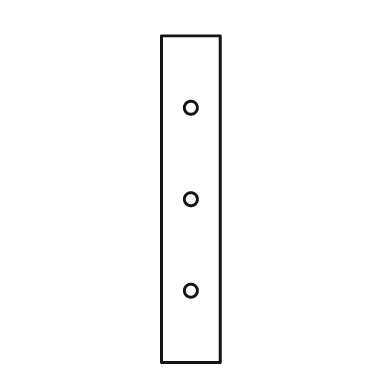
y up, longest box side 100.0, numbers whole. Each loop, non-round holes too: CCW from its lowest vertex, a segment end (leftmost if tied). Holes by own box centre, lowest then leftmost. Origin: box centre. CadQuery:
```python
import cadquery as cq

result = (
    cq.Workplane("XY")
    .moveTo(-9.0, -50.0)
    .lineTo(9.0, -50.0)
    .lineTo(9.0, 50.0)
    .lineTo(-9.0, 50.0)
    .close()
    .moveTo(0.0, -28.0)
    .circle(2.0)
    .moveTo(0.0, 0.0)
    .circle(2.0)
    .moveTo(0.0, 28.0)
    .circle(2.0)
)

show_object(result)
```